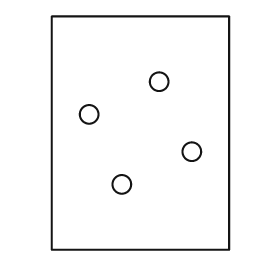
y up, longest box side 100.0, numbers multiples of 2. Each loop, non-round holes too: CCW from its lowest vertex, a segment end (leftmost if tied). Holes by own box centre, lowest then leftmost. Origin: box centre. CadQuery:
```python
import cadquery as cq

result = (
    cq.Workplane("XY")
    .moveTo(-38.0, -50.0)
    .lineTo(38.0, -50.0)
    .lineTo(38.0, 50.0)
    .lineTo(-38.0, 50.0)
    .close()
    .moveTo(-8.0, -22.0)
    .circle(4.0)
    .moveTo(22.0, -8.0)
    .circle(4.0)
    .moveTo(-22.0, 8.0)
    .circle(4.0)
    .moveTo(8.0, 22.0)
    .circle(4.0)
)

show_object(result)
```